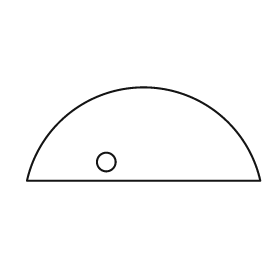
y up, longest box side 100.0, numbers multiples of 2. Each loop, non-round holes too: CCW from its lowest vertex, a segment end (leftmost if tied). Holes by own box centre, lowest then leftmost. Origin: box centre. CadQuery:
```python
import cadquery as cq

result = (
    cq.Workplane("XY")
    .moveTo(-50.0, -20.0)
    .lineTo(50.0, -20.0)
    .threePointArc((0.0, 20.0), (-50.0, -20.0))
    .close()
    .moveTo(-16.0, -12.0)
    .circle(4.0)
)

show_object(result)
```